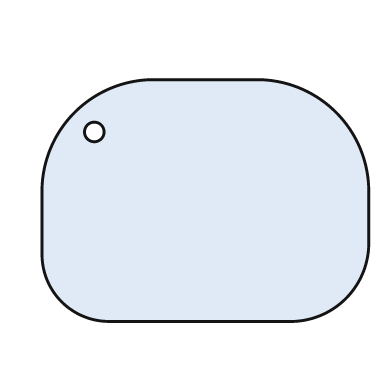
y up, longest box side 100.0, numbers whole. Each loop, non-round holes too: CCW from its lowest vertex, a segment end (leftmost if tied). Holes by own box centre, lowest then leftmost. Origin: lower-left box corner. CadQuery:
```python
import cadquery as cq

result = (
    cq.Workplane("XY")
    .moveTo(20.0, 0.0)
    .lineTo(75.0, 0.0)
    .threePointArc((93.0, 7.0), (100.0, 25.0))
    .lineTo(100.0, 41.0)
    .threePointArc((90.0, 64.0), (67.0, 74.0))
    .lineTo(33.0, 74.0)
    .threePointArc((10.0, 64.0), (0.0, 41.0))
    .lineTo(0.0, 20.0)
    .threePointArc((6.0, 6.0), (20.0, 0.0))
    .close()
    .moveTo(16.0, 58.0)
    .circle(3.0)
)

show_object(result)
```